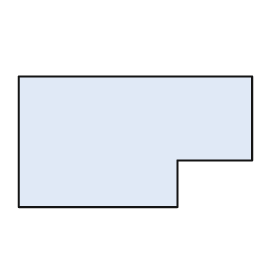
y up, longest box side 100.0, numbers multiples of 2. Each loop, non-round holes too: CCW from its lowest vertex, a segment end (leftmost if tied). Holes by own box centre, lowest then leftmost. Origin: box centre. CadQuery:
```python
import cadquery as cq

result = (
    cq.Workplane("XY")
    .moveTo(-50.0, -28.0)
    .lineTo(18.0, -28.0)
    .lineTo(18.0, -8.0)
    .lineTo(50.0, -8.0)
    .lineTo(50.0, 28.0)
    .lineTo(-50.0, 28.0)
    .close()
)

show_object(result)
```